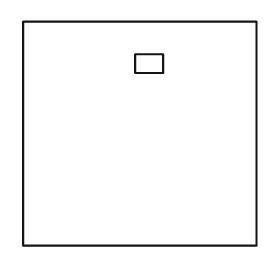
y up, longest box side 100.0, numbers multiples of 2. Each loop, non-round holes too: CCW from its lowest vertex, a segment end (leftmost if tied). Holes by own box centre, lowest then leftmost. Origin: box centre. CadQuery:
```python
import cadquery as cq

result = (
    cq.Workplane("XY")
    .moveTo(-50.0, -48.0)
    .lineTo(50.0, -48.0)
    .lineTo(50.0, 48.0)
    .lineTo(-50.0, 48.0)
    .close()
    .moveTo(-2.0, 26.0)
    .lineTo(10.0, 26.0)
    .lineTo(10.0, 34.0)
    .lineTo(-2.0, 34.0)
    .close()
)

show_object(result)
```